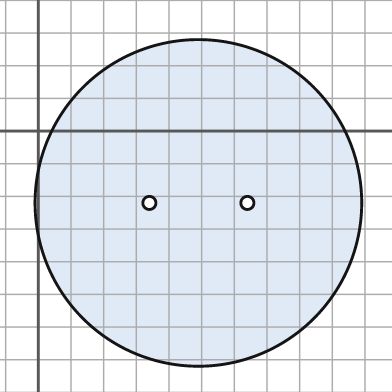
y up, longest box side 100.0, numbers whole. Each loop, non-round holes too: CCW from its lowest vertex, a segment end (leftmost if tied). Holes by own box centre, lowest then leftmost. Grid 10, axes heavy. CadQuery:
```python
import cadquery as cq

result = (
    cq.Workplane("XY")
    .moveTo(49.0, -22.0)
    .circle(50.0)
    .moveTo(34.0, -22.0)
    .circle(2.0)
    .moveTo(64.0, -22.0)
    .circle(2.0)
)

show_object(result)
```